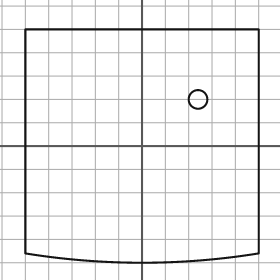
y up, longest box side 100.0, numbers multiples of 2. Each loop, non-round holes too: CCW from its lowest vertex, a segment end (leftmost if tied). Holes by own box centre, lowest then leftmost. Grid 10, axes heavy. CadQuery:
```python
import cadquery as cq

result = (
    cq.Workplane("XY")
    .moveTo(-50.0, -46.0)
    .threePointArc((0.0, -50.0), (50.0, -46.0))
    .lineTo(50.0, 50.0)
    .lineTo(-50.0, 50.0)
    .close()
    .moveTo(24.0, 20.0)
    .circle(4.0)
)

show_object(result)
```